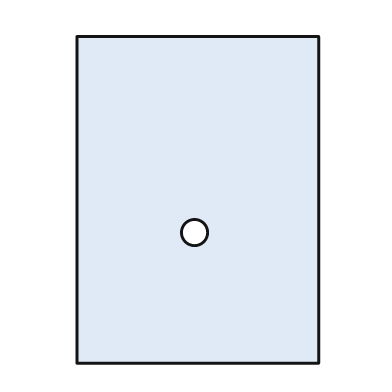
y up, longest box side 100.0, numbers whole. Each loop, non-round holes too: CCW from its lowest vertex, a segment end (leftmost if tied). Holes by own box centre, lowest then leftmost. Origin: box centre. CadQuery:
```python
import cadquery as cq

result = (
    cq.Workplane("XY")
    .moveTo(-37.0, -50.0)
    .lineTo(37.0, -50.0)
    .lineTo(37.0, 50.0)
    .lineTo(-37.0, 50.0)
    .close()
    .moveTo(-1.0, -10.0)
    .circle(4.0)
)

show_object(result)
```